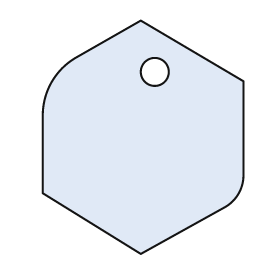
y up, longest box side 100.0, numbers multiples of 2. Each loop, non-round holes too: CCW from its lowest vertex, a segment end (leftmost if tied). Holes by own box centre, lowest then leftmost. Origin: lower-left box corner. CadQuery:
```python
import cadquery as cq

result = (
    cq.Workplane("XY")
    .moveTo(42.0, 0.0)
    .lineTo(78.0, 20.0)
    .threePointArc((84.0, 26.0), (86.0, 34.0))
    .lineTo(86.0, 74.0)
    .lineTo(42.0, 100.0)
    .lineTo(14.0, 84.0)
    .threePointArc((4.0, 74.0), (0.0, 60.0))
    .lineTo(0.0, 26.0)
    .close()
    .moveTo(48.0, 78.0)
    .circle(6.0)
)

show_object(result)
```